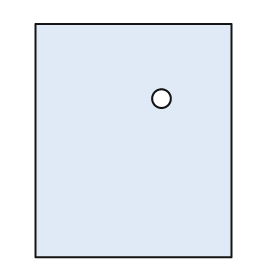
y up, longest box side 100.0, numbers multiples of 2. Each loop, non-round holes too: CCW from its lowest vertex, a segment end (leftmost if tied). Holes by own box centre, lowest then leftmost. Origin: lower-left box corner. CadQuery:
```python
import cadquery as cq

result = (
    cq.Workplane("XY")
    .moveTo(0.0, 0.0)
    .lineTo(84.0, 0.0)
    .lineTo(84.0, 100.0)
    .lineTo(0.0, 100.0)
    .close()
    .moveTo(54.0, 68.0)
    .circle(4.0)
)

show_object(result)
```